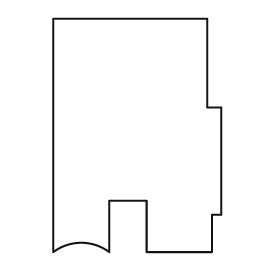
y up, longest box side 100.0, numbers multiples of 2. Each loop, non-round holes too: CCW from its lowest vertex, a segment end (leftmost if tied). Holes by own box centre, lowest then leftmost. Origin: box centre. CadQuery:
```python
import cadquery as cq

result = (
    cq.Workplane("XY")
    .moveTo(-36.0, -50.0)
    .threePointArc((-24.0, -46.0), (-12.0, -50.0))
    .lineTo(-12.0, -28.0)
    .lineTo(4.0, -28.0)
    .lineTo(4.0, -50.0)
    .lineTo(32.0, -50.0)
    .lineTo(32.0, -34.0)
    .lineTo(36.0, -34.0)
    .lineTo(36.0, 12.0)
    .lineTo(30.0, 12.0)
    .lineTo(30.0, 50.0)
    .lineTo(-36.0, 50.0)
    .close()
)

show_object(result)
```